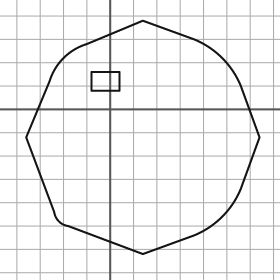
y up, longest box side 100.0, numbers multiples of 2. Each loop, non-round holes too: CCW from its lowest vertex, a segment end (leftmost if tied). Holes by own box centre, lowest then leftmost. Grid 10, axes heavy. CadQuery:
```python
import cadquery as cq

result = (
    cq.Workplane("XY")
    .moveTo(14.0, -62.0)
    .lineTo(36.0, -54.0)
    .threePointArc((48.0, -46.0), (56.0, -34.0))
    .lineTo(64.0, -12.0)
    .lineTo(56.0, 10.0)
    .threePointArc((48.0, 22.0), (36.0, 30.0))
    .lineTo(14.0, 38.0)
    .lineTo(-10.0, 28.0)
    .threePointArc((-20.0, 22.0), (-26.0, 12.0))
    .lineTo(-36.0, -12.0)
    .lineTo(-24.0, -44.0)
    .threePointArc((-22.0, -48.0), (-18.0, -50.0))
    .close()
    .moveTo(-8.0, 8.0)
    .lineTo(4.0, 8.0)
    .lineTo(4.0, 16.0)
    .lineTo(-8.0, 16.0)
    .close()
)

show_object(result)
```